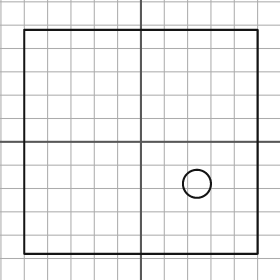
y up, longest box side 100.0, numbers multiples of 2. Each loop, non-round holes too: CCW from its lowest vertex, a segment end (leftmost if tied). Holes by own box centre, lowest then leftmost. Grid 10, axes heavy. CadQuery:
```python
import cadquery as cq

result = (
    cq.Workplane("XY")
    .moveTo(-50.0, -48.0)
    .lineTo(50.0, -48.0)
    .lineTo(50.0, 48.0)
    .lineTo(-50.0, 48.0)
    .close()
    .moveTo(24.0, -18.0)
    .circle(6.0)
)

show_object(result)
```